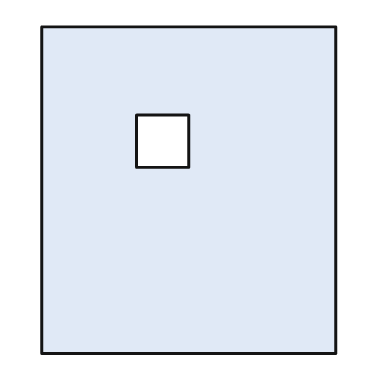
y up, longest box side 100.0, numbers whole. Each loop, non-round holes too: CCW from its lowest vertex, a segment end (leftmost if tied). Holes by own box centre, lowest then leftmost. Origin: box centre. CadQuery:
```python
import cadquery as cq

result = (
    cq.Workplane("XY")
    .moveTo(-45.0, -50.0)
    .lineTo(45.0, -50.0)
    .lineTo(45.0, 50.0)
    .lineTo(-45.0, 50.0)
    .close()
    .moveTo(-16.0, 7.0)
    .lineTo(0.0, 7.0)
    .lineTo(0.0, 23.0)
    .lineTo(-16.0, 23.0)
    .close()
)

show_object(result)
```